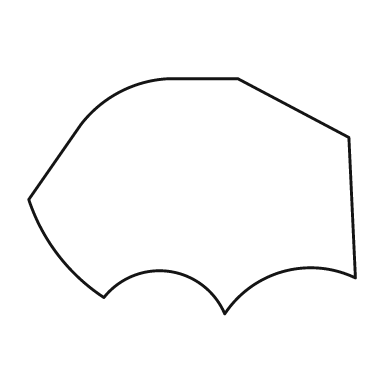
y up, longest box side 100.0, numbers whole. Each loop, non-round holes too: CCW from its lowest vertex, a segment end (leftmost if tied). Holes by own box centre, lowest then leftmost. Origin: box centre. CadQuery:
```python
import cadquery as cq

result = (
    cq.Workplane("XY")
    .moveTo(10.0, -36.0)
    .threePointArc((28.0, -23.0), (50.0, -25.0))
    .lineTo(48.0, 18.0)
    .lineTo(14.0, 36.0)
    .lineTo(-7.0, 36.0)
    .threePointArc((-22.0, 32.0), (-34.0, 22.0))
    .lineTo(-50.0, -1.0)
    .threePointArc((-41.0, -18.0), (-27.0, -31.0))
    .threePointArc((-7.0, -23.0), (10.0, -36.0))
    .close()
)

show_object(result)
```